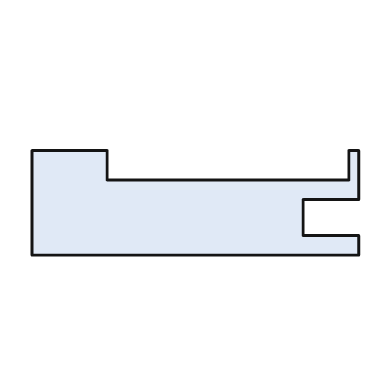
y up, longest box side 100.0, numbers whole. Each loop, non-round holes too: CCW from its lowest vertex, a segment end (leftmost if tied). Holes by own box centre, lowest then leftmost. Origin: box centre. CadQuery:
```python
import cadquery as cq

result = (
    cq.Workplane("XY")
    .moveTo(-50.0, -16.0)
    .lineTo(50.0, -16.0)
    .lineTo(50.0, -10.0)
    .lineTo(33.0, -10.0)
    .lineTo(33.0, 1.0)
    .lineTo(50.0, 1.0)
    .lineTo(50.0, 16.0)
    .lineTo(47.0, 16.0)
    .lineTo(47.0, 7.0)
    .lineTo(-27.0, 7.0)
    .lineTo(-27.0, 16.0)
    .lineTo(-50.0, 16.0)
    .close()
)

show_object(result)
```